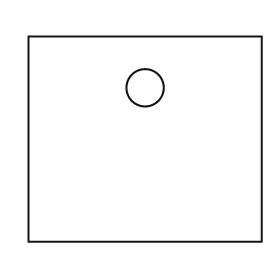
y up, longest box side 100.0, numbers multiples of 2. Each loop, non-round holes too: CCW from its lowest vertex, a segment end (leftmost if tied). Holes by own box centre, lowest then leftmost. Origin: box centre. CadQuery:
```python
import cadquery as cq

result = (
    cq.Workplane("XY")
    .moveTo(-50.0, -44.0)
    .lineTo(50.0, -44.0)
    .lineTo(50.0, 44.0)
    .lineTo(-50.0, 44.0)
    .close()
    .moveTo(0.0, 22.0)
    .circle(8.0)
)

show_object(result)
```